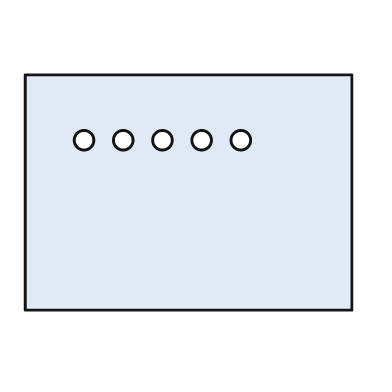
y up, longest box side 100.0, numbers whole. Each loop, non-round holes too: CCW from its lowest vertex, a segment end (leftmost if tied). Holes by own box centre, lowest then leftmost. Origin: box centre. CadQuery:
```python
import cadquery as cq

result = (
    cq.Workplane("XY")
    .moveTo(-50.0, -36.0)
    .lineTo(50.0, -36.0)
    .lineTo(50.0, 36.0)
    .lineTo(-50.0, 36.0)
    .close()
    .moveTo(-32.0, 16.0)
    .circle(3.0)
    .moveTo(-20.0, 16.0)
    .circle(3.0)
    .moveTo(-8.0, 16.0)
    .circle(3.0)
    .moveTo(4.0, 16.0)
    .circle(3.0)
    .moveTo(16.0, 16.0)
    .circle(3.0)
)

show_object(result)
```